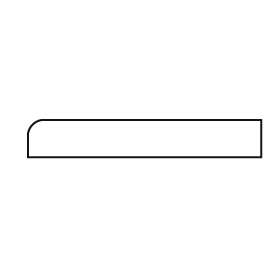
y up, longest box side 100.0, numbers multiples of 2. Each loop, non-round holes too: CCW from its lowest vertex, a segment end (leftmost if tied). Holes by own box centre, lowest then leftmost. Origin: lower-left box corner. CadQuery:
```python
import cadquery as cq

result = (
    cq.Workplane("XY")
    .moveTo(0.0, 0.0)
    .lineTo(100.0, 0.0)
    .lineTo(100.0, 16.0)
    .lineTo(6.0, 16.0)
    .threePointArc((2.0, 14.0), (0.0, 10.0))
    .close()
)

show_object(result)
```